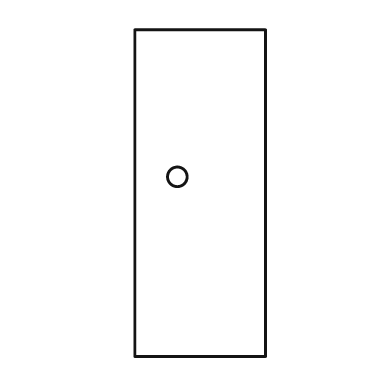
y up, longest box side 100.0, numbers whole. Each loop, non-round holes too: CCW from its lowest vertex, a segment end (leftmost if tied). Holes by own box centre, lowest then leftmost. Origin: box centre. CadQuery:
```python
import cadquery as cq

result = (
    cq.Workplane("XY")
    .moveTo(-20.0, -50.0)
    .lineTo(20.0, -50.0)
    .lineTo(20.0, 50.0)
    .lineTo(-20.0, 50.0)
    .close()
    .moveTo(-7.0, 5.0)
    .circle(3.0)
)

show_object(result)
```